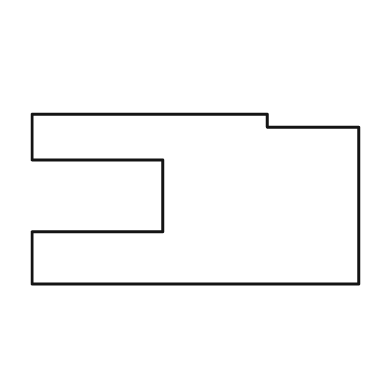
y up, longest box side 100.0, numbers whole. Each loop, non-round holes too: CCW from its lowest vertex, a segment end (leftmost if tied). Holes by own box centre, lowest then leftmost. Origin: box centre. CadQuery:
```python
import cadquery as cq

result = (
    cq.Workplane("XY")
    .moveTo(-50.0, -26.0)
    .lineTo(50.0, -26.0)
    .lineTo(50.0, 22.0)
    .lineTo(22.0, 22.0)
    .lineTo(22.0, 26.0)
    .lineTo(-50.0, 26.0)
    .lineTo(-50.0, 12.0)
    .lineTo(-10.0, 12.0)
    .lineTo(-10.0, -10.0)
    .lineTo(-50.0, -10.0)
    .close()
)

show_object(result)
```